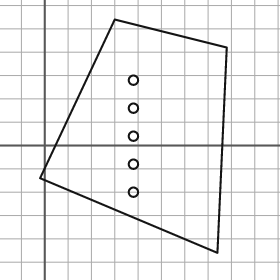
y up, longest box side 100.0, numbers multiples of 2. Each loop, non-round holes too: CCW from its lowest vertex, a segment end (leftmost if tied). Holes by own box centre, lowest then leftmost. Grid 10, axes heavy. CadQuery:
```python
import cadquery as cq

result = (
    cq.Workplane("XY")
    .moveTo(74.0, -46.0)
    .lineTo(78.0, 42.0)
    .lineTo(30.0, 54.0)
    .lineTo(-2.0, -14.0)
    .close()
    .moveTo(38.0, -20.0)
    .circle(2.0)
    .moveTo(38.0, -8.0)
    .circle(2.0)
    .moveTo(38.0, 4.0)
    .circle(2.0)
    .moveTo(38.0, 16.0)
    .circle(2.0)
    .moveTo(38.0, 28.0)
    .circle(2.0)
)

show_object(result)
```